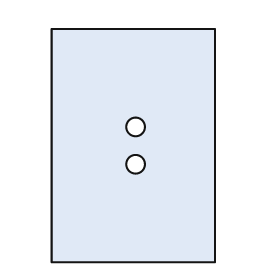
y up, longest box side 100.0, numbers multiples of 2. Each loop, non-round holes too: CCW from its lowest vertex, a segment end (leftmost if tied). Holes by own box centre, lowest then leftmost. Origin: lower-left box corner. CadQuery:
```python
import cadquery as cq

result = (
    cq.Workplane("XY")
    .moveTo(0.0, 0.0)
    .lineTo(70.0, 0.0)
    .lineTo(70.0, 100.0)
    .lineTo(0.0, 100.0)
    .close()
    .moveTo(36.0, 42.0)
    .circle(4.0)
    .moveTo(36.0, 58.0)
    .circle(4.0)
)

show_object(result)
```